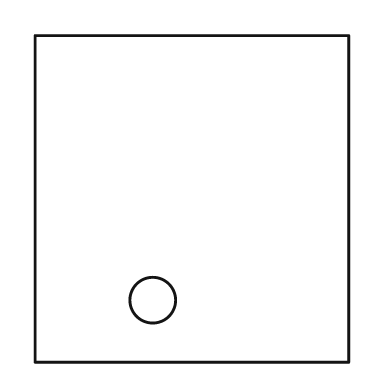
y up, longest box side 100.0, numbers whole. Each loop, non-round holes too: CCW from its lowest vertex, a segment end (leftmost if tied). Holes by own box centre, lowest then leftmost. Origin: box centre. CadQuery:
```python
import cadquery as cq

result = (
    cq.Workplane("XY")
    .moveTo(-48.0, -50.0)
    .lineTo(48.0, -50.0)
    .lineTo(48.0, 50.0)
    .lineTo(-48.0, 50.0)
    .close()
    .moveTo(-12.0, -31.0)
    .circle(7.0)
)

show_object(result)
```